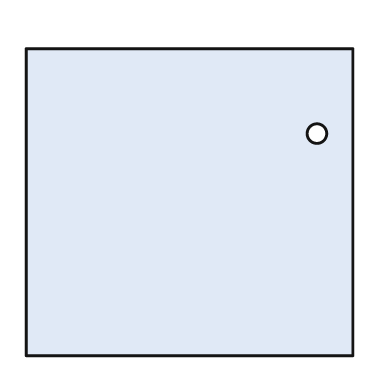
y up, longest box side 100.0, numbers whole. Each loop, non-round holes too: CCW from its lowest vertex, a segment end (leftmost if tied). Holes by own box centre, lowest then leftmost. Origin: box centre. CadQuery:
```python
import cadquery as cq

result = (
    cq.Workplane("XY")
    .moveTo(-50.0, -47.0)
    .lineTo(50.0, -47.0)
    .lineTo(50.0, 47.0)
    .lineTo(-50.0, 47.0)
    .close()
    .moveTo(39.0, 21.0)
    .circle(3.0)
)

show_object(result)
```